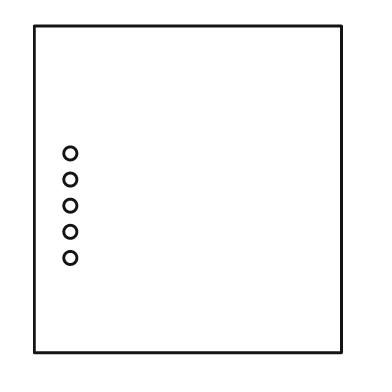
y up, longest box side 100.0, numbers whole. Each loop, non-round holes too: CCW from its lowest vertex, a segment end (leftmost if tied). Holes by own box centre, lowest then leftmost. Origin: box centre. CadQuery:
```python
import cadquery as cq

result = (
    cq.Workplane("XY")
    .moveTo(-47.0, -50.0)
    .lineTo(47.0, -50.0)
    .lineTo(47.0, 50.0)
    .lineTo(-47.0, 50.0)
    .close()
    .moveTo(-36.0, -21.0)
    .circle(2.0)
    .moveTo(-36.0, -13.0)
    .circle(2.0)
    .moveTo(-36.0, -5.0)
    .circle(2.0)
    .moveTo(-36.0, 3.0)
    .circle(2.0)
    .moveTo(-36.0, 11.0)
    .circle(2.0)
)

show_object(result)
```